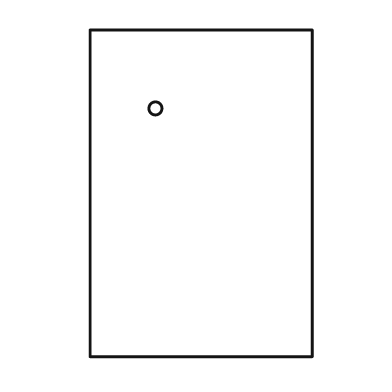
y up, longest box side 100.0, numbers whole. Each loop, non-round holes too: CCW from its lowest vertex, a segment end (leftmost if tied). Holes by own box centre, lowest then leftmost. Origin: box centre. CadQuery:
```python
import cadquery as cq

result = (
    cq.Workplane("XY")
    .moveTo(-34.0, -50.0)
    .lineTo(34.0, -50.0)
    .lineTo(34.0, 50.0)
    .lineTo(-34.0, 50.0)
    .close()
    .moveTo(-14.0, 26.0)
    .circle(2.0)
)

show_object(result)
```